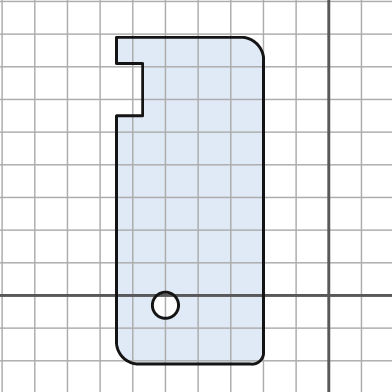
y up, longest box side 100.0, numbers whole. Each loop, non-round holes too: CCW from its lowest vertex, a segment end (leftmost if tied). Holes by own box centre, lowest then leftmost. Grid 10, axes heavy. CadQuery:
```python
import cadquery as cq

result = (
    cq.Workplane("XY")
    .moveTo(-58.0, -21.0)
    .lineTo(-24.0, -21.0)
    .threePointArc((-21.0, -20.0), (-20.0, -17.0))
    .lineTo(-20.0, 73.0)
    .threePointArc((-22.0, 77.0), (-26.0, 79.0))
    .lineTo(-65.0, 79.0)
    .lineTo(-65.0, 71.0)
    .lineTo(-57.0, 71.0)
    .lineTo(-57.0, 55.0)
    .lineTo(-65.0, 55.0)
    .lineTo(-65.0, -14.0)
    .threePointArc((-63.0, -19.0), (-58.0, -21.0))
    .close()
    .moveTo(-50.0, -3.0)
    .circle(4.0)
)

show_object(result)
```